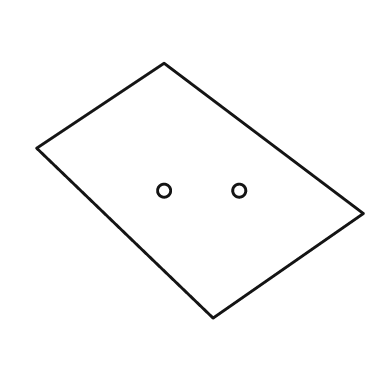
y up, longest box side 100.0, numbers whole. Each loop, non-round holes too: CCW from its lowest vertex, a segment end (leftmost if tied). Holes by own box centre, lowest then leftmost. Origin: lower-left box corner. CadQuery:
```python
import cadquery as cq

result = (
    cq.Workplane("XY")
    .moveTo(54.0, 0.0)
    .lineTo(100.0, 32.0)
    .lineTo(39.0, 78.0)
    .lineTo(0.0, 52.0)
    .close()
    .moveTo(39.0, 39.0)
    .circle(2.0)
    .moveTo(62.0, 39.0)
    .circle(2.0)
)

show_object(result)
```